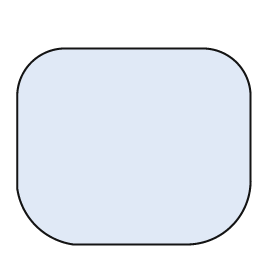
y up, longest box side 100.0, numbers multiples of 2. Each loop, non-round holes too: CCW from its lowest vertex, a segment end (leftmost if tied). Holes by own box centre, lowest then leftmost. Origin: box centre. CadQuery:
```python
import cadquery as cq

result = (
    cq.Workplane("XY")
    .moveTo(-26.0, -42.0)
    .lineTo(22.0, -42.0)
    .threePointArc((42.0, -34.0), (50.0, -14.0))
    .lineTo(50.0, 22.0)
    .threePointArc((44.0, 36.0), (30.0, 42.0))
    .lineTo(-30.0, 42.0)
    .threePointArc((-44.0, 36.0), (-50.0, 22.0))
    .lineTo(-50.0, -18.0)
    .threePointArc((-42.0, -34.0), (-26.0, -42.0))
    .close()
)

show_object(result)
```